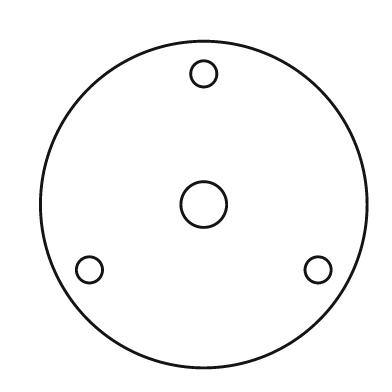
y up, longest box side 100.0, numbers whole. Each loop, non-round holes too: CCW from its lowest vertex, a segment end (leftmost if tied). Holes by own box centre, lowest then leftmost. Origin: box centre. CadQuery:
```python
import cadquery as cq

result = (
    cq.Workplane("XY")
    .moveTo(0.0, 0.0)
    .circle(50.0)
    .moveTo(-35.0, -20.0)
    .circle(4.0)
    .moveTo(35.0, -20.0)
    .circle(4.0)
    .moveTo(0.0, 0.0)
    .circle(7.0)
    .moveTo(0.0, 40.0)
    .circle(4.0)
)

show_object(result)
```